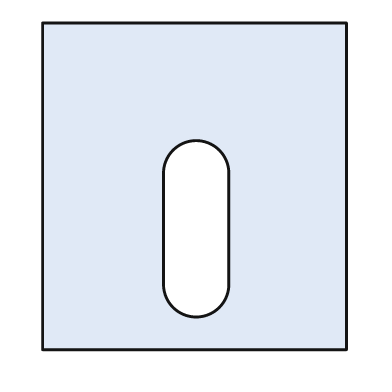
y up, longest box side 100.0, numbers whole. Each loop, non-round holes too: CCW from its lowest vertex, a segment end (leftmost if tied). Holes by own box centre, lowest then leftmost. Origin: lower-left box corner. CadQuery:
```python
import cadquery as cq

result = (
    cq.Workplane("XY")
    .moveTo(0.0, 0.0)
    .lineTo(93.0, 0.0)
    .lineTo(93.0, 100.0)
    .lineTo(0.0, 100.0)
    .close()
    .moveTo(37.0, 20.0)
    .threePointArc((47.0, 10.0), (57.0, 20.0))
    .lineTo(57.0, 54.0)
    .threePointArc((47.0, 64.0), (37.0, 54.0))
    .close()
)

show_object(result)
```